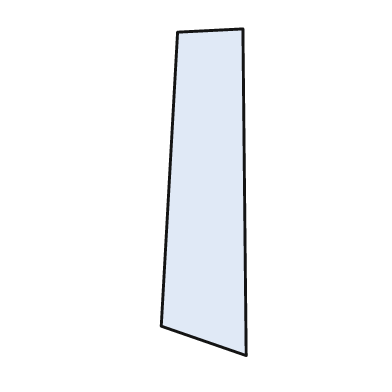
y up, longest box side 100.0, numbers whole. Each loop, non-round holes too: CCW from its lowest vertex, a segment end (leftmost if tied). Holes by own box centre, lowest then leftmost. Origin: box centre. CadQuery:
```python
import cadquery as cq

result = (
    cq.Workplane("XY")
    .moveTo(13.0, -50.0)
    .lineTo(12.0, 50.0)
    .lineTo(-8.0, 49.0)
    .lineTo(-13.0, -41.0)
    .close()
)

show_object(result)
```